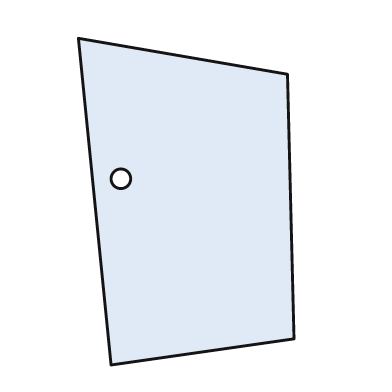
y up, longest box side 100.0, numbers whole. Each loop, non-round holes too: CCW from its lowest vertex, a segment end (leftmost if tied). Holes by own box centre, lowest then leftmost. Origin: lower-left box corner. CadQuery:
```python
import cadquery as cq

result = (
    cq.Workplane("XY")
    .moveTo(10.0, 0.0)
    .lineTo(66.0, 8.0)
    .lineTo(64.0, 89.0)
    .lineTo(0.0, 100.0)
    .close()
    .moveTo(13.0, 57.0)
    .circle(3.0)
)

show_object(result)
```